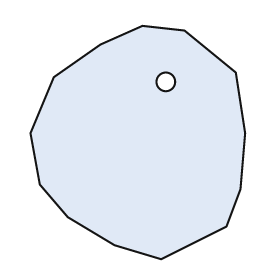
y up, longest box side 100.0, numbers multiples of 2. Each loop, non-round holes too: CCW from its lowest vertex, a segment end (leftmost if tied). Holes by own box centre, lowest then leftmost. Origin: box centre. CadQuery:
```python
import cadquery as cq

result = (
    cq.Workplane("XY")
    .moveTo(10.0, -50.0)
    .lineTo(38.0, -36.0)
    .lineTo(44.0, -20.0)
    .lineTo(46.0, 4.0)
    .lineTo(42.0, 30.0)
    .lineTo(20.0, 48.0)
    .lineTo(2.0, 50.0)
    .lineTo(-16.0, 42.0)
    .lineTo(-36.0, 28.0)
    .lineTo(-46.0, 4.0)
    .lineTo(-42.0, -18.0)
    .lineTo(-30.0, -32.0)
    .lineTo(-10.0, -44.0)
    .close()
    .moveTo(12.0, 26.0)
    .circle(4.0)
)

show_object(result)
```